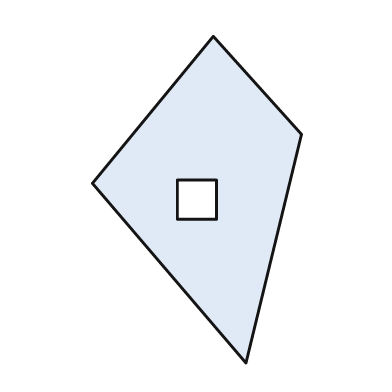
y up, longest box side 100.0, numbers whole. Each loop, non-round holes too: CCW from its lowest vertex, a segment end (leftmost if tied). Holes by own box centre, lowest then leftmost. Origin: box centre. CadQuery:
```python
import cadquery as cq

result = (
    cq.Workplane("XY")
    .moveTo(15.0, -50.0)
    .lineTo(32.0, 20.0)
    .lineTo(5.0, 50.0)
    .lineTo(-32.0, 5.0)
    .close()
    .moveTo(-6.0, -6.0)
    .lineTo(6.0, -6.0)
    .lineTo(6.0, 6.0)
    .lineTo(-6.0, 6.0)
    .close()
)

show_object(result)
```